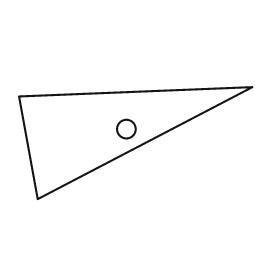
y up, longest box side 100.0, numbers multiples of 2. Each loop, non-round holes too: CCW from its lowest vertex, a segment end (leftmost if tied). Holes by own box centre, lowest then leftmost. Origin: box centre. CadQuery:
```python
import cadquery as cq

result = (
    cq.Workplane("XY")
    .moveTo(-42.0, -24.0)
    .lineTo(50.0, 24.0)
    .lineTo(-50.0, 20.0)
    .close()
    .moveTo(-4.0, 6.0)
    .circle(4.0)
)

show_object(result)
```